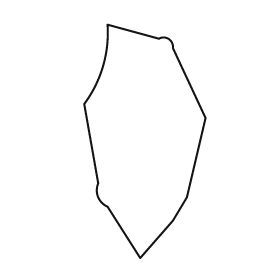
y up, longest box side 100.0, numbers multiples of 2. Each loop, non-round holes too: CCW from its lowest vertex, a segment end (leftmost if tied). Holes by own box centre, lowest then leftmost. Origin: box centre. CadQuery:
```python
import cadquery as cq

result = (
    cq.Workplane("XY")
    .moveTo(-2.0, -50.0)
    .lineTo(12.0, -34.0)
    .lineTo(18.0, -24.0)
    .lineTo(26.0, 10.0)
    .lineTo(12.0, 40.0)
    .threePointArc((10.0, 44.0), (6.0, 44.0))
    .lineTo(-16.0, 50.0)
    .threePointArc((-18.0, 32.0), (-26.0, 16.0))
    .lineTo(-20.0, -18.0)
    .threePointArc((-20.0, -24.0), (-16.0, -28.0))
    .close()
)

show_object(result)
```